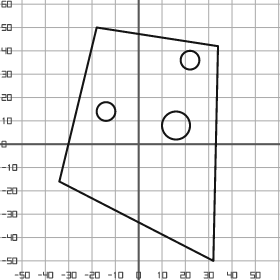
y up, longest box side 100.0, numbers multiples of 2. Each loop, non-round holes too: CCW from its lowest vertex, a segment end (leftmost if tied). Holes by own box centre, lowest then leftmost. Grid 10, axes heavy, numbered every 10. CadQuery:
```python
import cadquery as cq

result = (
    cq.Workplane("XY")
    .moveTo(32.0, -50.0)
    .lineTo(34.0, 42.0)
    .lineTo(-18.0, 50.0)
    .lineTo(-34.0, -16.0)
    .close()
    .moveTo(16.0, 8.0)
    .circle(6.0)
    .moveTo(-14.0, 14.0)
    .circle(4.0)
    .moveTo(22.0, 36.0)
    .circle(4.0)
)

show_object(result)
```